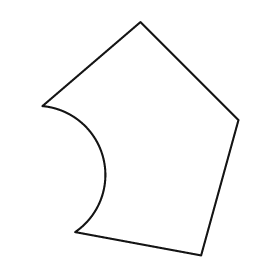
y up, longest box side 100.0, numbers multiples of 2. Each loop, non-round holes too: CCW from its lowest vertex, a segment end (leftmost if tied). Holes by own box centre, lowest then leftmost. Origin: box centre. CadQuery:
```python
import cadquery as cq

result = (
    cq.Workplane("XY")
    .moveTo(26.0, -50.0)
    .lineTo(42.0, 8.0)
    .lineTo(0.0, 50.0)
    .lineTo(-42.0, 14.0)
    .threePointArc((-16.0, -8.0), (-28.0, -40.0))
    .close()
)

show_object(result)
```